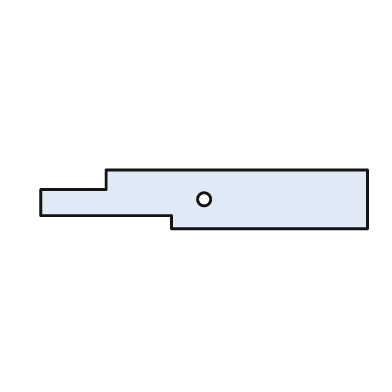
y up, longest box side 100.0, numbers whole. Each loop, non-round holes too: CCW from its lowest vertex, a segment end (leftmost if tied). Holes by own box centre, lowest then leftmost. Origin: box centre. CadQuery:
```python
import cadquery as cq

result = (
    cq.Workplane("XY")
    .moveTo(-10.0, -9.0)
    .lineTo(50.0, -9.0)
    .lineTo(50.0, 9.0)
    .lineTo(-30.0, 9.0)
    .lineTo(-30.0, 3.0)
    .lineTo(-50.0, 3.0)
    .lineTo(-50.0, -5.0)
    .lineTo(-10.0, -5.0)
    .close()
    .moveTo(0.0, 0.0)
    .circle(2.0)
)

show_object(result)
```